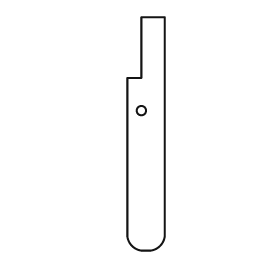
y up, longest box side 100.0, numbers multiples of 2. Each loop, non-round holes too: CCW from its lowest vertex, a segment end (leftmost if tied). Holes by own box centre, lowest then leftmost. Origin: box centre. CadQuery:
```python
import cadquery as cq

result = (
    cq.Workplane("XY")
    .moveTo(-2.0, -50.0)
    .lineTo(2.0, -50.0)
    .threePointArc((6.0, -48.0), (8.0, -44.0))
    .lineTo(8.0, 50.0)
    .lineTo(-2.0, 50.0)
    .lineTo(-2.0, 24.0)
    .lineTo(-8.0, 24.0)
    .lineTo(-8.0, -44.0)
    .threePointArc((-6.0, -48.0), (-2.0, -50.0))
    .close()
    .moveTo(-2.0, 10.0)
    .circle(2.0)
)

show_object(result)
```